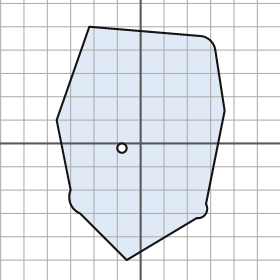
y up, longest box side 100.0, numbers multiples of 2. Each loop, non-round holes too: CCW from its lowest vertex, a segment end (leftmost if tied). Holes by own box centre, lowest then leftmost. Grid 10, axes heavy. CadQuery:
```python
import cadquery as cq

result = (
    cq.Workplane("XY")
    .moveTo(-6.0, -50.0)
    .lineTo(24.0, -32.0)
    .threePointArc((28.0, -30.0), (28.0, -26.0))
    .lineTo(36.0, 14.0)
    .lineTo(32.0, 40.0)
    .threePointArc((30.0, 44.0), (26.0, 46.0))
    .lineTo(-22.0, 50.0)
    .lineTo(-36.0, 10.0)
    .lineTo(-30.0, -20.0)
    .threePointArc((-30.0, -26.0), (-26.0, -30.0))
    .close()
    .moveTo(-8.0, -2.0)
    .circle(2.0)
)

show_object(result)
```